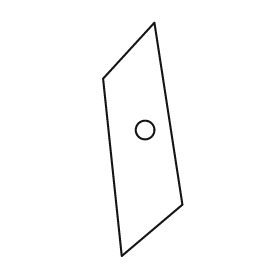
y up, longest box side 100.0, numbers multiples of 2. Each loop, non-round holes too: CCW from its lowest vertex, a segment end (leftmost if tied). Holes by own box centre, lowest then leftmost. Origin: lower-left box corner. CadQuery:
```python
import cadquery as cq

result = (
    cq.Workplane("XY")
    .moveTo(8.0, 0.0)
    .lineTo(34.0, 22.0)
    .lineTo(22.0, 100.0)
    .lineTo(0.0, 76.0)
    .close()
    .moveTo(18.0, 54.0)
    .circle(4.0)
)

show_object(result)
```